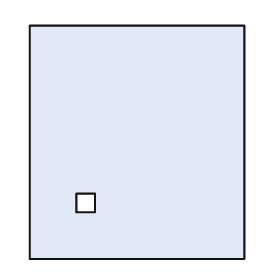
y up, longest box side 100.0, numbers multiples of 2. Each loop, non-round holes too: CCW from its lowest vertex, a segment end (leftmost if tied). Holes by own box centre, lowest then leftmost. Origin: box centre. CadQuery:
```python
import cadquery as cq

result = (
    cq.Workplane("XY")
    .moveTo(-46.0, -50.0)
    .lineTo(46.0, -50.0)
    .lineTo(46.0, 50.0)
    .lineTo(-46.0, 50.0)
    .close()
    .moveTo(-26.0, -30.0)
    .lineTo(-18.0, -30.0)
    .lineTo(-18.0, -22.0)
    .lineTo(-26.0, -22.0)
    .close()
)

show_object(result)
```